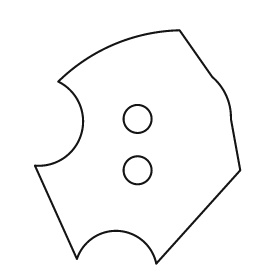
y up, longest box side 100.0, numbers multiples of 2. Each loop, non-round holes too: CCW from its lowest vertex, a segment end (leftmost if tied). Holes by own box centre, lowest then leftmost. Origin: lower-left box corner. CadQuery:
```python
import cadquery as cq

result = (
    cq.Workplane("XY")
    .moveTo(52.0, 0.0)
    .lineTo(88.0, 40.0)
    .lineTo(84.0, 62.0)
    .threePointArc((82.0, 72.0), (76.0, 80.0))
    .lineTo(62.0, 100.0)
    .threePointArc((34.0, 94.0), (10.0, 78.0))
    .threePointArc((20.0, 56.0), (0.0, 42.0))
    .lineTo(18.0, 2.0)
    .threePointArc((36.0, 14.0), (52.0, 0.0))
    .close()
    .moveTo(44.0, 40.0)
    .circle(6.0)
    .moveTo(44.0, 62.0)
    .circle(6.0)
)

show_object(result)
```